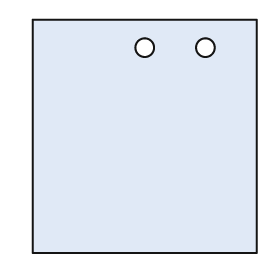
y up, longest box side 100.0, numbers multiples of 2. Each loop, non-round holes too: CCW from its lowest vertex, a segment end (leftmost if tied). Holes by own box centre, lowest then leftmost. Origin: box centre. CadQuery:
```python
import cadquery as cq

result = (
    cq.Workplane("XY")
    .moveTo(-48.0, -50.0)
    .lineTo(48.0, -50.0)
    .lineTo(48.0, 50.0)
    .lineTo(-48.0, 50.0)
    .close()
    .moveTo(0.0, 38.0)
    .circle(4.0)
    .moveTo(26.0, 38.0)
    .circle(4.0)
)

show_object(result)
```